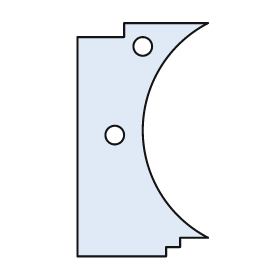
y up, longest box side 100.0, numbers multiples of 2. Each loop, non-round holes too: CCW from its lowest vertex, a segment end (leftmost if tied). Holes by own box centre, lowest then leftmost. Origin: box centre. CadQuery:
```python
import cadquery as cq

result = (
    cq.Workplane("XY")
    .moveTo(-28.0, -50.0)
    .lineTo(10.0, -50.0)
    .lineTo(10.0, -46.0)
    .lineTo(16.0, -46.0)
    .lineTo(16.0, -42.0)
    .lineTo(28.0, -42.0)
    .threePointArc((0.0, 4.0), (28.0, 50.0))
    .lineTo(-8.0, 50.0)
    .lineTo(-8.0, 44.0)
    .lineTo(-28.0, 44.0)
    .close()
    .moveTo(-12.0, 2.0)
    .circle(4.0)
    .moveTo(0.0, 40.0)
    .circle(4.0)
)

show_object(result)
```